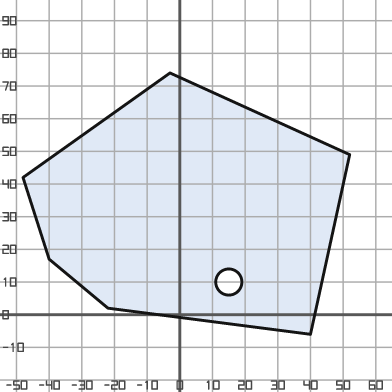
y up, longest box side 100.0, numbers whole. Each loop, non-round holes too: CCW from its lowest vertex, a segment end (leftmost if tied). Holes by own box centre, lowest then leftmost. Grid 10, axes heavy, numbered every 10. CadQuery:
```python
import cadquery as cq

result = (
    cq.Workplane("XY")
    .moveTo(40.0, -6.0)
    .lineTo(52.0, 49.0)
    .lineTo(-3.0, 74.0)
    .lineTo(-48.0, 42.0)
    .lineTo(-40.0, 17.0)
    .lineTo(-22.0, 2.0)
    .close()
    .moveTo(15.0, 10.0)
    .circle(4.0)
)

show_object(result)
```